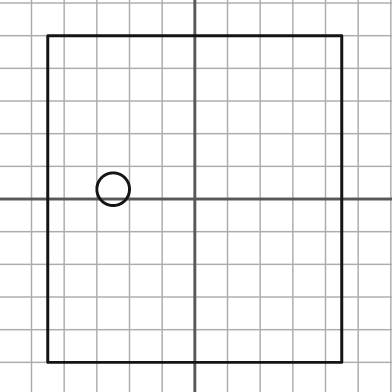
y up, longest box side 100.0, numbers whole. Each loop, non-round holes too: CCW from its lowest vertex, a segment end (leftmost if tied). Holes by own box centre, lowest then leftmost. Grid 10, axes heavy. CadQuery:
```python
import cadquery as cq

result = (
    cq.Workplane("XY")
    .moveTo(-45.0, -50.0)
    .lineTo(45.0, -50.0)
    .lineTo(45.0, 50.0)
    .lineTo(-45.0, 50.0)
    .close()
    .moveTo(-25.0, 3.0)
    .circle(5.0)
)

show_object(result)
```